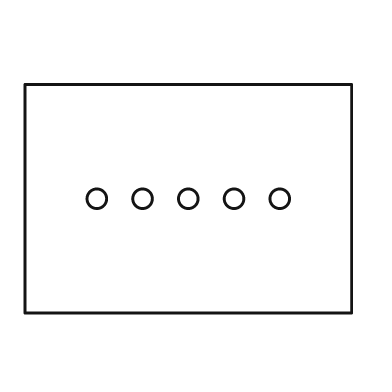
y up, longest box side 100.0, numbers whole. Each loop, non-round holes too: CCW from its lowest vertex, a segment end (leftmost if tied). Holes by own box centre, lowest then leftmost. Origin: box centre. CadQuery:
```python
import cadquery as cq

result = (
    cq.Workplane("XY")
    .moveTo(-50.0, -35.0)
    .lineTo(50.0, -35.0)
    .lineTo(50.0, 35.0)
    .lineTo(-50.0, 35.0)
    .close()
    .moveTo(-28.0, 0.0)
    .circle(3.0)
    .moveTo(-14.0, 0.0)
    .circle(3.0)
    .moveTo(0.0, 0.0)
    .circle(3.0)
    .moveTo(14.0, 0.0)
    .circle(3.0)
    .moveTo(28.0, 0.0)
    .circle(3.0)
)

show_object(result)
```